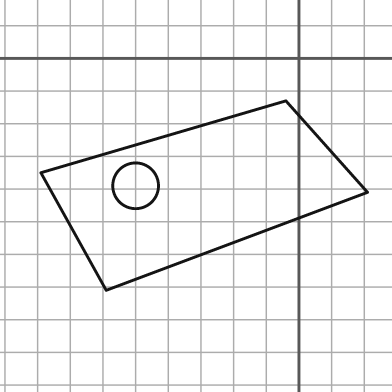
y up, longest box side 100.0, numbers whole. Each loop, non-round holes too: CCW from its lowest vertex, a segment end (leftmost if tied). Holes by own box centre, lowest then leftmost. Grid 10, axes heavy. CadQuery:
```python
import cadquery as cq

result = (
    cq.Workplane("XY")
    .moveTo(-59.0, -71.0)
    .lineTo(21.0, -41.0)
    .lineTo(-4.0, -13.0)
    .lineTo(-79.0, -35.0)
    .close()
    .moveTo(-50.0, -39.0)
    .circle(7.0)
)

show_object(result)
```